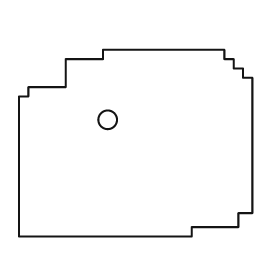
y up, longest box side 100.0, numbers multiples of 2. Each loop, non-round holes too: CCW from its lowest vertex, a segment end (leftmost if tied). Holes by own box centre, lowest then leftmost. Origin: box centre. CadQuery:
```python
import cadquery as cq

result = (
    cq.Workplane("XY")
    .moveTo(-50.0, -40.0)
    .lineTo(24.0, -40.0)
    .lineTo(24.0, -36.0)
    .lineTo(44.0, -36.0)
    .lineTo(44.0, -30.0)
    .lineTo(50.0, -30.0)
    .lineTo(50.0, 28.0)
    .lineTo(46.0, 28.0)
    .lineTo(46.0, 32.0)
    .lineTo(42.0, 32.0)
    .lineTo(42.0, 36.0)
    .lineTo(38.0, 36.0)
    .lineTo(38.0, 40.0)
    .lineTo(-14.0, 40.0)
    .lineTo(-14.0, 36.0)
    .lineTo(-30.0, 36.0)
    .lineTo(-30.0, 24.0)
    .lineTo(-46.0, 24.0)
    .lineTo(-46.0, 20.0)
    .lineTo(-50.0, 20.0)
    .close()
    .moveTo(-12.0, 10.0)
    .circle(4.0)
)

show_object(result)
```